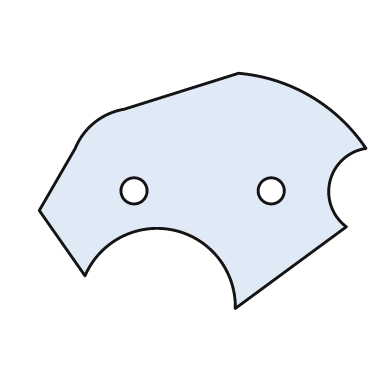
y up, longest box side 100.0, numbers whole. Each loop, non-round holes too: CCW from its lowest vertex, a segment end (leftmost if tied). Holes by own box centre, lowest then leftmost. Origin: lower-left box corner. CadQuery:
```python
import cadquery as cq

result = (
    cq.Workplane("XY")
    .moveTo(60.0, 0.0)
    .lineTo(94.0, 25.0)
    .threePointArc((89.0, 39.0), (100.0, 49.0))
    .threePointArc((83.0, 65.0), (61.0, 72.0))
    .lineTo(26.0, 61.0)
    .threePointArc((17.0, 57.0), (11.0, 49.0))
    .lineTo(0.0, 30.0)
    .lineTo(14.0, 10.0)
    .threePointArc((41.0, 24.0), (60.0, 0.0))
    .close()
    .moveTo(29.0, 36.0)
    .circle(4.0)
    .moveTo(71.0, 36.0)
    .circle(4.0)
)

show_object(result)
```